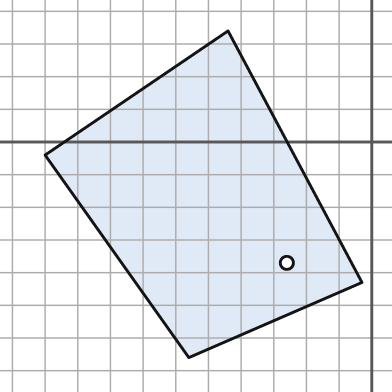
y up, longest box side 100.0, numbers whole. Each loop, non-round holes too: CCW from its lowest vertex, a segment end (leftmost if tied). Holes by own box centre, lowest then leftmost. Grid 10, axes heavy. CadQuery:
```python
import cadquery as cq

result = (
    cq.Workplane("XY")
    .moveTo(-56.0, -66.0)
    .lineTo(-3.0, -43.0)
    .lineTo(-44.0, 34.0)
    .lineTo(-100.0, -4.0)
    .close()
    .moveTo(-26.0, -37.0)
    .circle(2.0)
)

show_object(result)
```